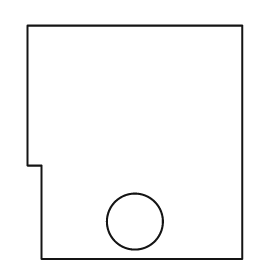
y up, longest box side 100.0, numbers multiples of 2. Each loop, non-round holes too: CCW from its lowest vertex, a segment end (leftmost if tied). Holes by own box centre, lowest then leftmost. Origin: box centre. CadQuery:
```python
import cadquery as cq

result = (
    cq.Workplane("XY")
    .moveTo(-40.0, -50.0)
    .lineTo(46.0, -50.0)
    .lineTo(46.0, 50.0)
    .lineTo(-46.0, 50.0)
    .lineTo(-46.0, -10.0)
    .lineTo(-40.0, -10.0)
    .close()
    .moveTo(0.0, -34.0)
    .circle(12.0)
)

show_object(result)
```